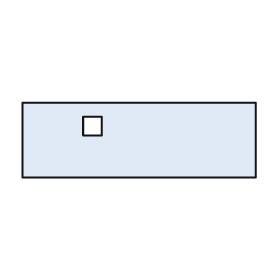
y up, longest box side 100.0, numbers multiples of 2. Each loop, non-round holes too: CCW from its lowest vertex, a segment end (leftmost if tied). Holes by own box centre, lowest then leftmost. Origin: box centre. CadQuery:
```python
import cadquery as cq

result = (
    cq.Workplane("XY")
    .moveTo(-50.0, -16.0)
    .lineTo(50.0, -16.0)
    .lineTo(50.0, 16.0)
    .lineTo(-50.0, 16.0)
    .close()
    .moveTo(-24.0, 2.0)
    .lineTo(-16.0, 2.0)
    .lineTo(-16.0, 10.0)
    .lineTo(-24.0, 10.0)
    .close()
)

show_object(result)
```